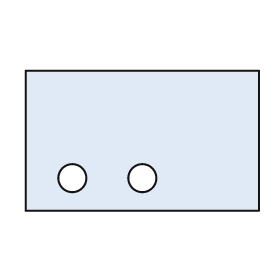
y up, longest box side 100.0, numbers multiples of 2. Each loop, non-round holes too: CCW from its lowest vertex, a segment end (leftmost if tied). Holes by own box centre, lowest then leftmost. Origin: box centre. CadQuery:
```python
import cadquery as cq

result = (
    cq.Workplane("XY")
    .moveTo(-50.0, -30.0)
    .lineTo(50.0, -30.0)
    .lineTo(50.0, 30.0)
    .lineTo(-50.0, 30.0)
    .close()
    .moveTo(-30.0, -16.0)
    .circle(6.0)
    .moveTo(0.0, -16.0)
    .circle(6.0)
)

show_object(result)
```